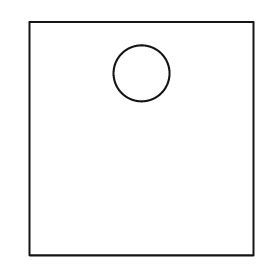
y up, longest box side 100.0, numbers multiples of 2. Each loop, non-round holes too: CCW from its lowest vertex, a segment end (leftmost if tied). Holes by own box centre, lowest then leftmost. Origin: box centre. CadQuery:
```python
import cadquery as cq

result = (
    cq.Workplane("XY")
    .moveTo(-48.0, -50.0)
    .lineTo(48.0, -50.0)
    .lineTo(48.0, 50.0)
    .lineTo(-48.0, 50.0)
    .close()
    .moveTo(0.0, 28.0)
    .circle(12.0)
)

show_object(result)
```